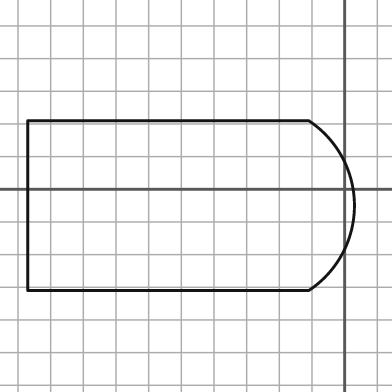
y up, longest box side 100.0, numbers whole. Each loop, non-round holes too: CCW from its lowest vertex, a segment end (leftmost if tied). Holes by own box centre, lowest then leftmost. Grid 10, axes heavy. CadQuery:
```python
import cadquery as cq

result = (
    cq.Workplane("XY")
    .moveTo(-97.0, -31.0)
    .lineTo(-11.0, -31.0)
    .threePointArc((3.0, -5.0), (-11.0, 21.0))
    .lineTo(-97.0, 21.0)
    .close()
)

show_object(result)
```